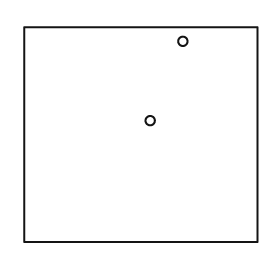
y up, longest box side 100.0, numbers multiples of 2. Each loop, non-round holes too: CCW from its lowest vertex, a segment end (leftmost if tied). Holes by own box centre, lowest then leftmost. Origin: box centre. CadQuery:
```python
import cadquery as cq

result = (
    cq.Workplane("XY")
    .moveTo(-50.0, -46.0)
    .lineTo(50.0, -46.0)
    .lineTo(50.0, 46.0)
    .lineTo(-50.0, 46.0)
    .close()
    .moveTo(4.0, 6.0)
    .circle(2.0)
    .moveTo(18.0, 40.0)
    .circle(2.0)
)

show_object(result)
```